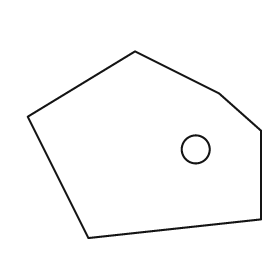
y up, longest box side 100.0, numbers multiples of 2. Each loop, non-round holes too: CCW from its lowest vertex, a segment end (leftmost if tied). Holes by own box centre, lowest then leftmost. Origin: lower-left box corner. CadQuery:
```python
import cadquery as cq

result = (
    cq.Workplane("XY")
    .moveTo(26.0, 0.0)
    .lineTo(100.0, 8.0)
    .lineTo(100.0, 46.0)
    .lineTo(82.0, 62.0)
    .lineTo(46.0, 80.0)
    .lineTo(0.0, 52.0)
    .close()
    .moveTo(72.0, 38.0)
    .circle(6.0)
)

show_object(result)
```